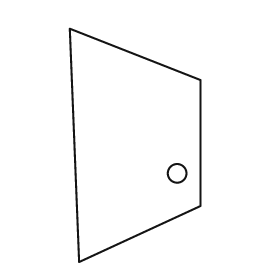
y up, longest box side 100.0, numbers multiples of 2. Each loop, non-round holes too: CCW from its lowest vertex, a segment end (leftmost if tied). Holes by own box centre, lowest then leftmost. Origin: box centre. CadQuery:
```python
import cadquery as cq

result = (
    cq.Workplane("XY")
    .moveTo(-24.0, -50.0)
    .lineTo(28.0, -26.0)
    .lineTo(28.0, 28.0)
    .lineTo(-28.0, 50.0)
    .close()
    .moveTo(18.0, -12.0)
    .circle(4.0)
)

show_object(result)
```